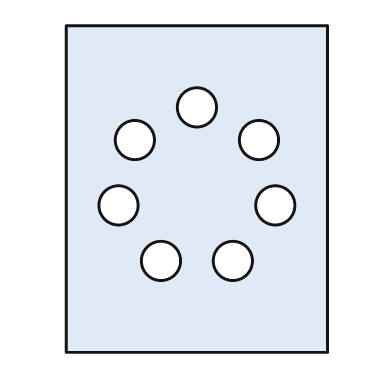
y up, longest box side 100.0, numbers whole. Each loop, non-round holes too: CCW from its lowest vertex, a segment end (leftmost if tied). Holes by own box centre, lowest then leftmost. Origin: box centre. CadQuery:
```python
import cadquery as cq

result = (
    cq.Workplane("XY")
    .moveTo(-40.0, -50.0)
    .lineTo(40.0, -50.0)
    .lineTo(40.0, 50.0)
    .lineTo(-40.0, 50.0)
    .close()
    .moveTo(-11.0, -22.0)
    .circle(6.0)
    .moveTo(11.0, -22.0)
    .circle(6.0)
    .moveTo(-24.0, -5.0)
    .circle(6.0)
    .moveTo(24.0, -5.0)
    .circle(6.0)
    .moveTo(-19.0, 15.0)
    .circle(6.0)
    .moveTo(19.0, 15.0)
    .circle(6.0)
    .moveTo(0.0, 25.0)
    .circle(6.0)
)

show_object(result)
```